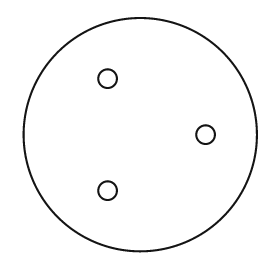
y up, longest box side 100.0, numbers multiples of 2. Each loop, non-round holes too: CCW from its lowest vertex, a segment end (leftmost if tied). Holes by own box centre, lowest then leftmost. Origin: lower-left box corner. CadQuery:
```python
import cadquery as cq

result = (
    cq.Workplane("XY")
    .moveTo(50.0, 50.0)
    .circle(50.0)
    .moveTo(36.0, 26.0)
    .circle(4.0)
    .moveTo(78.0, 50.0)
    .circle(4.0)
    .moveTo(36.0, 74.0)
    .circle(4.0)
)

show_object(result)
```